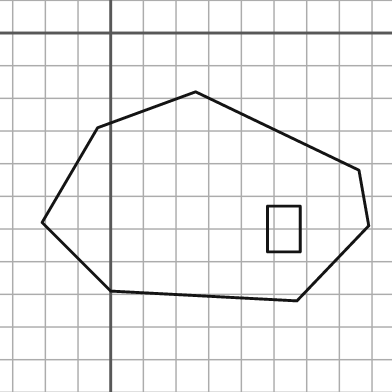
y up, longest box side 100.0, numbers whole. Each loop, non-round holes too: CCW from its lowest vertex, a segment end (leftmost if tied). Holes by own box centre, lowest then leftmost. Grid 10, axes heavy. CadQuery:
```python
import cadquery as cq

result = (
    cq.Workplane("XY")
    .moveTo(57.0, -82.0)
    .lineTo(79.0, -59.0)
    .lineTo(76.0, -42.0)
    .lineTo(26.0, -18.0)
    .lineTo(-4.0, -29.0)
    .lineTo(-21.0, -58.0)
    .lineTo(0.0, -79.0)
    .close()
    .moveTo(48.0, -67.0)
    .lineTo(58.0, -67.0)
    .lineTo(58.0, -53.0)
    .lineTo(48.0, -53.0)
    .close()
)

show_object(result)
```